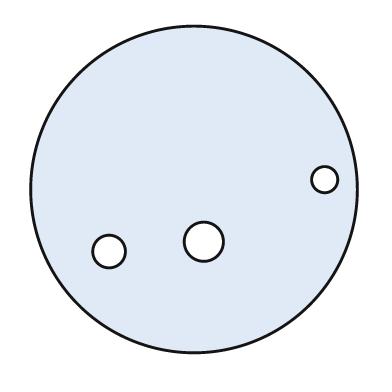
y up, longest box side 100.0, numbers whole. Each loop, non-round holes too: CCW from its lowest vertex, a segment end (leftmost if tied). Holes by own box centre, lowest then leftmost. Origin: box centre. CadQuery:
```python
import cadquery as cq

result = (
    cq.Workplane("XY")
    .moveTo(0.0, 0.0)
    .circle(50.0)
    .moveTo(-26.0, -19.0)
    .circle(5.0)
    .moveTo(3.0, -16.0)
    .circle(6.0)
    .moveTo(40.0, 3.0)
    .circle(4.0)
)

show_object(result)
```